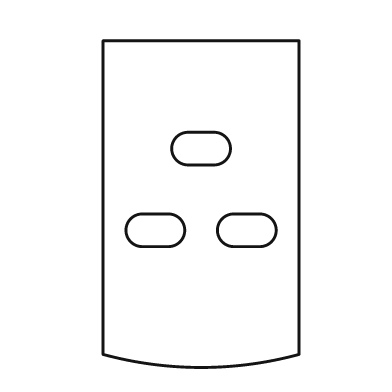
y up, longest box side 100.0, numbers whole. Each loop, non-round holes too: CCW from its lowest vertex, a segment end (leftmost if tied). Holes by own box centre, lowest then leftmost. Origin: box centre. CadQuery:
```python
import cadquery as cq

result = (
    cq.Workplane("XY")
    .moveTo(-30.0, -46.0)
    .threePointArc((0.0, -50.0), (30.0, -46.0))
    .lineTo(30.0, 50.0)
    .lineTo(-30.0, 50.0)
    .close()
    .moveTo(-18.0, -13.0)
    .lineTo(-10.0, -13.0)
    .threePointArc((-5.0, -8.0), (-10.0, -3.0))
    .lineTo(-18.0, -3.0)
    .threePointArc((-23.0, -8.0), (-18.0, -13.0))
    .close()
    .moveTo(10.0, -13.0)
    .lineTo(18.0, -13.0)
    .threePointArc((23.0, -8.0), (18.0, -3.0))
    .lineTo(10.0, -3.0)
    .threePointArc((5.0, -8.0), (10.0, -13.0))
    .close()
    .moveTo(-4.0, 12.0)
    .lineTo(4.0, 12.0)
    .threePointArc((9.0, 17.0), (4.0, 22.0))
    .lineTo(-4.0, 22.0)
    .threePointArc((-9.0, 17.0), (-4.0, 12.0))
    .close()
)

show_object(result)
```